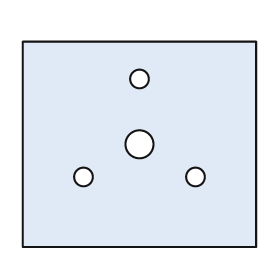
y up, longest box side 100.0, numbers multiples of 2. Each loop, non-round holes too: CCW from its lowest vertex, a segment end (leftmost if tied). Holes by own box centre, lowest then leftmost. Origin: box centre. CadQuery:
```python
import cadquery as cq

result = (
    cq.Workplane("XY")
    .moveTo(-50.0, -44.0)
    .lineTo(50.0, -44.0)
    .lineTo(50.0, 44.0)
    .lineTo(-50.0, 44.0)
    .close()
    .moveTo(-24.0, -14.0)
    .circle(4.0)
    .moveTo(24.0, -14.0)
    .circle(4.0)
    .moveTo(0.0, 0.0)
    .circle(6.0)
    .moveTo(0.0, 28.0)
    .circle(4.0)
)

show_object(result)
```